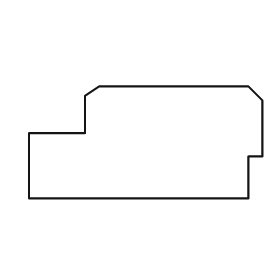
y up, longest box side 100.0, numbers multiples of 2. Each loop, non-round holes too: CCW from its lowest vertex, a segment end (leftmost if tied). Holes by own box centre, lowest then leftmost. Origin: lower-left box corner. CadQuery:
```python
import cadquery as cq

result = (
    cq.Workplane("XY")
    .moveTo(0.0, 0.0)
    .lineTo(94.0, 0.0)
    .lineTo(94.0, 18.0)
    .lineTo(100.0, 18.0)
    .lineTo(100.0, 42.0)
    .lineTo(94.0, 48.0)
    .lineTo(30.0, 48.0)
    .lineTo(24.0, 44.0)
    .lineTo(24.0, 28.0)
    .lineTo(0.0, 28.0)
    .close()
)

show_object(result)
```